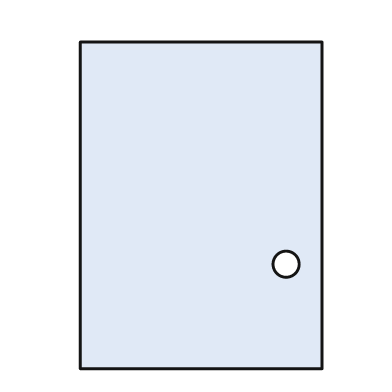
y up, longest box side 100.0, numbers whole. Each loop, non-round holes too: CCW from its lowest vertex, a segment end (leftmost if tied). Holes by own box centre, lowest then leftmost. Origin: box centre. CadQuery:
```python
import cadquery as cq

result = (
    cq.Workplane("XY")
    .moveTo(-37.0, -50.0)
    .lineTo(37.0, -50.0)
    .lineTo(37.0, 50.0)
    .lineTo(-37.0, 50.0)
    .close()
    .moveTo(26.0, -18.0)
    .circle(4.0)
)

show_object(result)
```